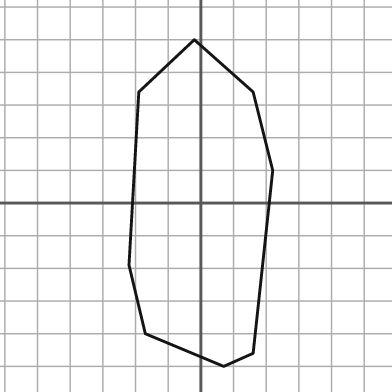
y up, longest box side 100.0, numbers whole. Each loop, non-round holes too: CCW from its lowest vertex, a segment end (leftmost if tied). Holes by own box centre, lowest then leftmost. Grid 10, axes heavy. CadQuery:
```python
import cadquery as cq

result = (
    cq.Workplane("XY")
    .moveTo(7.0, -50.0)
    .lineTo(16.0, -46.0)
    .lineTo(22.0, 10.0)
    .lineTo(16.0, 34.0)
    .lineTo(-2.0, 50.0)
    .lineTo(-19.0, 34.0)
    .lineTo(-22.0, -19.0)
    .lineTo(-17.0, -40.0)
    .close()
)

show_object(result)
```